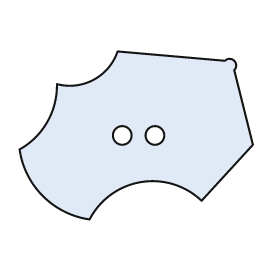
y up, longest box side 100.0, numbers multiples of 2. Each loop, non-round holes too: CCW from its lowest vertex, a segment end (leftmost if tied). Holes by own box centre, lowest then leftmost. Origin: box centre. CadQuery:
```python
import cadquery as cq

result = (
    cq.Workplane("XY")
    .moveTo(-20.0, -36.0)
    .threePointArc((2.0, -20.0), (28.0, -28.0))
    .lineTo(50.0, -4.0)
    .lineTo(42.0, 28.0)
    .threePointArc((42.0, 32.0), (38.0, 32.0))
    .lineTo(-8.0, 36.0)
    .threePointArc((-18.0, 24.0), (-34.0, 22.0))
    .threePointArc((-38.0, 6.0), (-50.0, -6.0))
    .threePointArc((-40.0, -26.0), (-20.0, -36.0))
    .close()
    .moveTo(-6.0, 0.0)
    .circle(4.0)
    .moveTo(8.0, 0.0)
    .circle(4.0)
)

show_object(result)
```